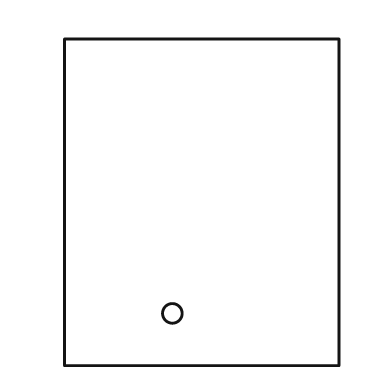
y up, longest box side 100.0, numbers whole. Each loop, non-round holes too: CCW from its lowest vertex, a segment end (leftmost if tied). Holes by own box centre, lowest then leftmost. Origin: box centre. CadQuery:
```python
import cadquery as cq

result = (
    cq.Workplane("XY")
    .moveTo(-42.0, -50.0)
    .lineTo(42.0, -50.0)
    .lineTo(42.0, 50.0)
    .lineTo(-42.0, 50.0)
    .close()
    .moveTo(-9.0, -34.0)
    .circle(3.0)
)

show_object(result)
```